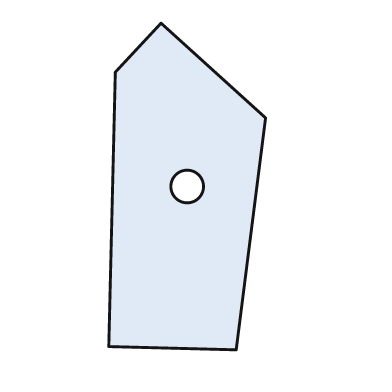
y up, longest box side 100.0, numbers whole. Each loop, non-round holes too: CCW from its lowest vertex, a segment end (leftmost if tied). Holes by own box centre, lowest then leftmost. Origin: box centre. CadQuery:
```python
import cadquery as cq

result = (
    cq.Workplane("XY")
    .moveTo(15.0, -50.0)
    .lineTo(24.0, 21.0)
    .lineTo(-8.0, 50.0)
    .lineTo(-22.0, 35.0)
    .lineTo(-24.0, -49.0)
    .close()
    .moveTo(0.0, 0.0)
    .circle(5.0)
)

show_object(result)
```